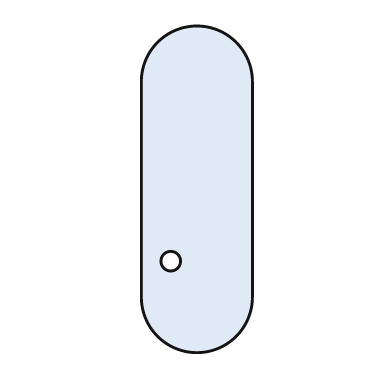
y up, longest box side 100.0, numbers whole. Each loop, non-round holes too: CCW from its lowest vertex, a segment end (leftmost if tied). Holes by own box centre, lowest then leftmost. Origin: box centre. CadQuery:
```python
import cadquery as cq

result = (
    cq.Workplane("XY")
    .moveTo(-17.0, -33.0)
    .threePointArc((0.0, -50.0), (17.0, -33.0))
    .lineTo(17.0, 33.0)
    .threePointArc((0.0, 50.0), (-17.0, 33.0))
    .close()
    .moveTo(-8.0, -22.0)
    .circle(3.0)
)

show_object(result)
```